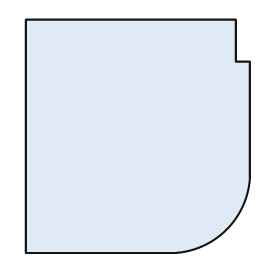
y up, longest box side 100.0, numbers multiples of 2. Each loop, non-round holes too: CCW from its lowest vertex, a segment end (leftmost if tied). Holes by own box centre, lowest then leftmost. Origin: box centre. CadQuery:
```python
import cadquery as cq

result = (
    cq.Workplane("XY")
    .moveTo(-48.0, -50.0)
    .lineTo(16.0, -50.0)
    .threePointArc((38.0, -40.0), (48.0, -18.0))
    .lineTo(48.0, 32.0)
    .lineTo(42.0, 32.0)
    .lineTo(42.0, 50.0)
    .lineTo(-48.0, 50.0)
    .close()
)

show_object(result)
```